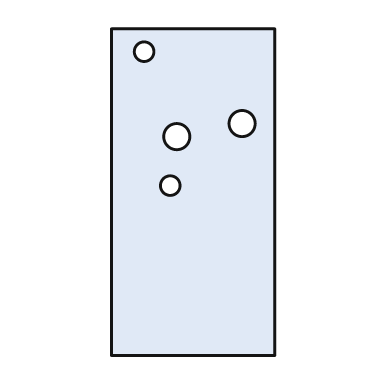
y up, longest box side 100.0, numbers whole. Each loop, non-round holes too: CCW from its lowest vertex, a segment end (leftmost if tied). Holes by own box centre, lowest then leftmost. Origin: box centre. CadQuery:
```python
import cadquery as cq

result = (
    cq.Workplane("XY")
    .moveTo(-25.0, -50.0)
    .lineTo(25.0, -50.0)
    .lineTo(25.0, 50.0)
    .lineTo(-25.0, 50.0)
    .close()
    .moveTo(-7.0, 2.0)
    .circle(3.0)
    .moveTo(-5.0, 17.0)
    .circle(4.0)
    .moveTo(15.0, 21.0)
    .circle(4.0)
    .moveTo(-15.0, 43.0)
    .circle(3.0)
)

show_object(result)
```